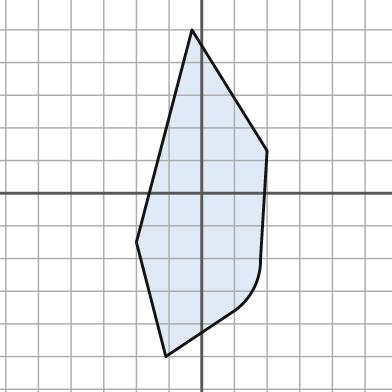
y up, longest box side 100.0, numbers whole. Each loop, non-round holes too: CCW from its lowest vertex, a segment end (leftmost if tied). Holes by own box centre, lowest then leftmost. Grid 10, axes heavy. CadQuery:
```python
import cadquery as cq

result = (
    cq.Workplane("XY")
    .moveTo(-11.0, -50.0)
    .lineTo(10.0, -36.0)
    .threePointArc((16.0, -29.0), (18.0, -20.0))
    .lineTo(20.0, 13.0)
    .lineTo(-3.0, 50.0)
    .lineTo(-20.0, -15.0)
    .close()
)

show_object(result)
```